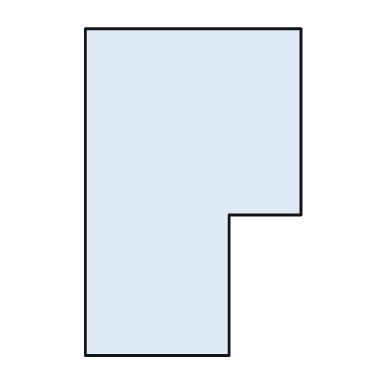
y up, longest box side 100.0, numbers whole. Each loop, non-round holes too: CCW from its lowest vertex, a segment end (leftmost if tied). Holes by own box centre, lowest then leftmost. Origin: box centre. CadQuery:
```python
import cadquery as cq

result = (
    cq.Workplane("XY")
    .moveTo(-33.0, -50.0)
    .lineTo(11.0, -50.0)
    .lineTo(11.0, -7.0)
    .lineTo(33.0, -7.0)
    .lineTo(33.0, 50.0)
    .lineTo(-33.0, 50.0)
    .close()
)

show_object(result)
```